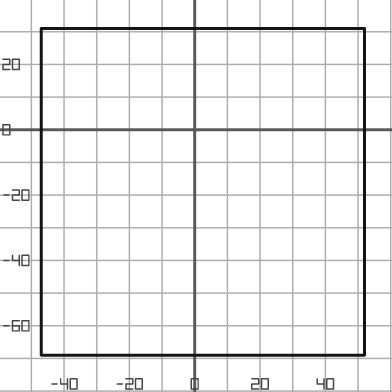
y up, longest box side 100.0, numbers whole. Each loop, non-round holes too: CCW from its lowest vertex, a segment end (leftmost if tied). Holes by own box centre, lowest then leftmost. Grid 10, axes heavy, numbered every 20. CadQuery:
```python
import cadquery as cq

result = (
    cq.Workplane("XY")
    .moveTo(-47.0, -69.0)
    .lineTo(52.0, -69.0)
    .lineTo(52.0, 31.0)
    .lineTo(-47.0, 31.0)
    .close()
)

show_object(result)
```